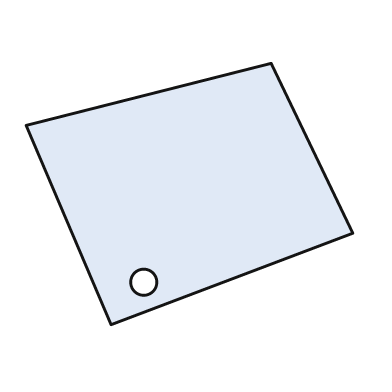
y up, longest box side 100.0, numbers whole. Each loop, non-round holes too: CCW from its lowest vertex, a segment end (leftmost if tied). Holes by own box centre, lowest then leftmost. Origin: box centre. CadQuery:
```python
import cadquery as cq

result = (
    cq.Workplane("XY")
    .moveTo(-24.0, -40.0)
    .lineTo(50.0, -12.0)
    .lineTo(25.0, 40.0)
    .lineTo(-50.0, 21.0)
    .close()
    .moveTo(-14.0, -27.0)
    .circle(4.0)
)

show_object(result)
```